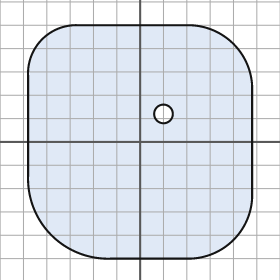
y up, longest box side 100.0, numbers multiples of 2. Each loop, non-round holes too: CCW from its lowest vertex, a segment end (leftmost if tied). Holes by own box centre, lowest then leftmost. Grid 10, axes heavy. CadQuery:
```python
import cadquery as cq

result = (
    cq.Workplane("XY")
    .moveTo(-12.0, -50.0)
    .lineTo(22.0, -50.0)
    .threePointArc((40.0, -42.0), (48.0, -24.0))
    .lineTo(48.0, 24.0)
    .threePointArc((40.0, 42.0), (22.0, 50.0))
    .lineTo(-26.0, 50.0)
    .threePointArc((-42.0, 44.0), (-48.0, 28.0))
    .lineTo(-48.0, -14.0)
    .threePointArc((-38.0, -40.0), (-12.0, -50.0))
    .close()
    .moveTo(10.0, 12.0)
    .circle(4.0)
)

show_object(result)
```